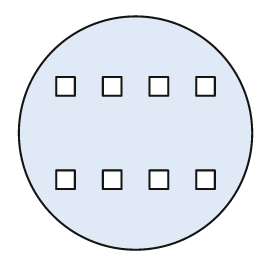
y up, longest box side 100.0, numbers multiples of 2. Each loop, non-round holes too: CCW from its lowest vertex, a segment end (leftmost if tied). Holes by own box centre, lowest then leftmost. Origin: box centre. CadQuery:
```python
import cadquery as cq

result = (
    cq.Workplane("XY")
    .moveTo(0.0, 0.0)
    .circle(50.0)
    .moveTo(-34.0, -24.0)
    .lineTo(-26.0, -24.0)
    .lineTo(-26.0, -16.0)
    .lineTo(-34.0, -16.0)
    .close()
    .moveTo(-14.0, -24.0)
    .lineTo(-6.0, -24.0)
    .lineTo(-6.0, -16.0)
    .lineTo(-14.0, -16.0)
    .close()
    .moveTo(6.0, -24.0)
    .lineTo(14.0, -24.0)
    .lineTo(14.0, -16.0)
    .lineTo(6.0, -16.0)
    .close()
    .moveTo(26.0, -24.0)
    .lineTo(34.0, -24.0)
    .lineTo(34.0, -16.0)
    .lineTo(26.0, -16.0)
    .close()
    .moveTo(-34.0, 16.0)
    .lineTo(-26.0, 16.0)
    .lineTo(-26.0, 24.0)
    .lineTo(-34.0, 24.0)
    .close()
    .moveTo(-14.0, 16.0)
    .lineTo(-6.0, 16.0)
    .lineTo(-6.0, 24.0)
    .lineTo(-14.0, 24.0)
    .close()
    .moveTo(6.0, 16.0)
    .lineTo(14.0, 16.0)
    .lineTo(14.0, 24.0)
    .lineTo(6.0, 24.0)
    .close()
    .moveTo(26.0, 16.0)
    .lineTo(34.0, 16.0)
    .lineTo(34.0, 24.0)
    .lineTo(26.0, 24.0)
    .close()
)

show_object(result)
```